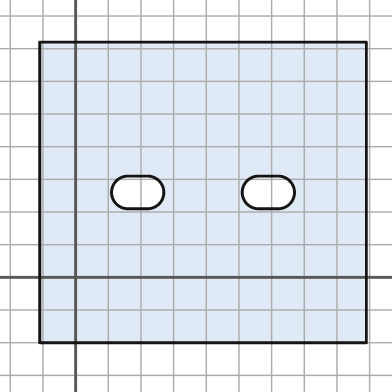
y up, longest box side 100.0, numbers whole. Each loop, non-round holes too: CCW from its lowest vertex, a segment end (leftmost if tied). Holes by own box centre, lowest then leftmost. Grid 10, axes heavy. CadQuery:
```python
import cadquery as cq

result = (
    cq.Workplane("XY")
    .moveTo(-11.0, -20.0)
    .lineTo(89.0, -20.0)
    .lineTo(89.0, 72.0)
    .lineTo(-11.0, 72.0)
    .close()
    .moveTo(16.0, 21.0)
    .lineTo(22.0, 21.0)
    .threePointArc((27.0, 26.0), (22.0, 31.0))
    .lineTo(16.0, 31.0)
    .threePointArc((11.0, 26.0), (16.0, 21.0))
    .close()
    .moveTo(56.0, 21.0)
    .lineTo(62.0, 21.0)
    .threePointArc((67.0, 26.0), (62.0, 31.0))
    .lineTo(56.0, 31.0)
    .threePointArc((51.0, 26.0), (56.0, 21.0))
    .close()
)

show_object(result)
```